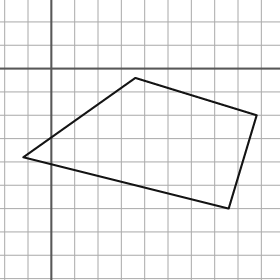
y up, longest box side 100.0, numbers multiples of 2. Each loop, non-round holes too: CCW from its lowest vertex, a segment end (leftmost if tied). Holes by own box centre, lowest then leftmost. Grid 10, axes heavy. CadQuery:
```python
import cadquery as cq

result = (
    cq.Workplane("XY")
    .moveTo(76.0, -60.0)
    .lineTo(88.0, -20.0)
    .lineTo(36.0, -4.0)
    .lineTo(-12.0, -38.0)
    .close()
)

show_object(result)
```